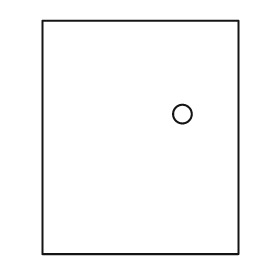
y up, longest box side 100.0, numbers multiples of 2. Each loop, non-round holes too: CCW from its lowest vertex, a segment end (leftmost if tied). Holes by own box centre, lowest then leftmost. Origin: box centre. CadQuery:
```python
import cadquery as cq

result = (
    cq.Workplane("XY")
    .moveTo(-42.0, -50.0)
    .lineTo(42.0, -50.0)
    .lineTo(42.0, 50.0)
    .lineTo(-42.0, 50.0)
    .close()
    .moveTo(18.0, 10.0)
    .circle(4.0)
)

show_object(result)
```